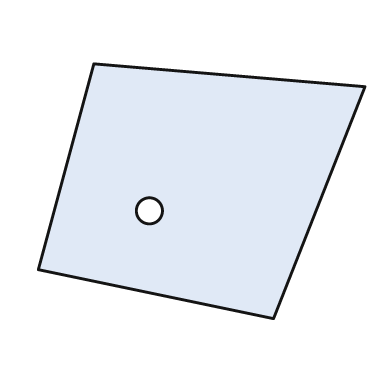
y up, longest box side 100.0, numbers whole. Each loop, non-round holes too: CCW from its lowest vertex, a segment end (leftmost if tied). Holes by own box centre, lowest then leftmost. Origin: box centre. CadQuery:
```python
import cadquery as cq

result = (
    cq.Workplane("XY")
    .moveTo(22.0, -39.0)
    .lineTo(50.0, 32.0)
    .lineTo(-33.0, 39.0)
    .lineTo(-50.0, -24.0)
    .close()
    .moveTo(-16.0, -6.0)
    .circle(4.0)
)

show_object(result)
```